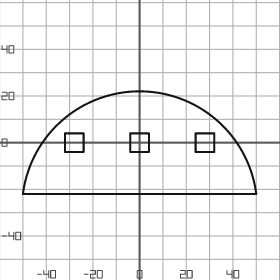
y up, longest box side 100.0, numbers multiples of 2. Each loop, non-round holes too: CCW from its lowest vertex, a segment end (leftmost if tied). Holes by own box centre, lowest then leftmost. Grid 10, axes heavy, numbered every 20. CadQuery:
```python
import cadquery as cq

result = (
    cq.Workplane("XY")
    .moveTo(-50.0, -22.0)
    .lineTo(50.0, -22.0)
    .threePointArc((0.0, 22.0), (-50.0, -22.0))
    .close()
    .moveTo(-32.0, -4.0)
    .lineTo(-24.0, -4.0)
    .lineTo(-24.0, 4.0)
    .lineTo(-32.0, 4.0)
    .close()
    .moveTo(-4.0, -4.0)
    .lineTo(4.0, -4.0)
    .lineTo(4.0, 4.0)
    .lineTo(-4.0, 4.0)
    .close()
    .moveTo(24.0, -4.0)
    .lineTo(32.0, -4.0)
    .lineTo(32.0, 4.0)
    .lineTo(24.0, 4.0)
    .close()
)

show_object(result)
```